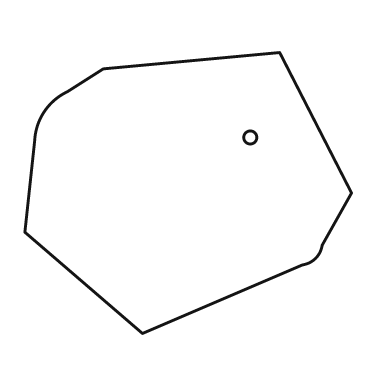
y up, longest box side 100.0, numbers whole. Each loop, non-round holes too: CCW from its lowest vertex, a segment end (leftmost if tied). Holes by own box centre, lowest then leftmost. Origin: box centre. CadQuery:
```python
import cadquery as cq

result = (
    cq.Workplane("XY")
    .moveTo(-14.0, -43.0)
    .lineTo(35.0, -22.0)
    .threePointArc((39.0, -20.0), (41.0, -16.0))
    .lineTo(50.0, 0.0)
    .lineTo(28.0, 43.0)
    .lineTo(-26.0, 38.0)
    .lineTo(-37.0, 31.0)
    .threePointArc((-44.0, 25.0), (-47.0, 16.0))
    .lineTo(-50.0, -12.0)
    .close()
    .moveTo(19.0, 17.0)
    .circle(2.0)
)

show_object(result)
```